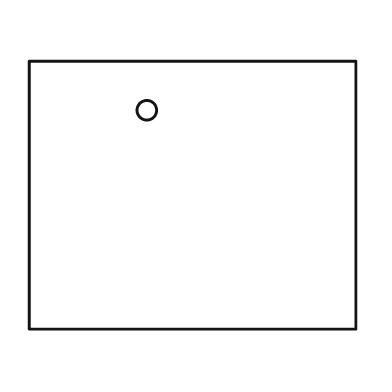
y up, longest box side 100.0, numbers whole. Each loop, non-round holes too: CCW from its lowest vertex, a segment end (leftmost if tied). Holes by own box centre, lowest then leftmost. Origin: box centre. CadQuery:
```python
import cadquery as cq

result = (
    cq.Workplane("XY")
    .moveTo(-50.0, -41.0)
    .lineTo(50.0, -41.0)
    .lineTo(50.0, 41.0)
    .lineTo(-50.0, 41.0)
    .close()
    .moveTo(-14.0, 26.0)
    .circle(3.0)
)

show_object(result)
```